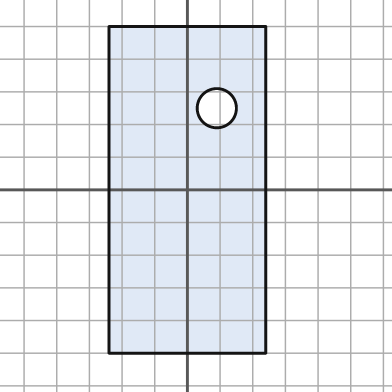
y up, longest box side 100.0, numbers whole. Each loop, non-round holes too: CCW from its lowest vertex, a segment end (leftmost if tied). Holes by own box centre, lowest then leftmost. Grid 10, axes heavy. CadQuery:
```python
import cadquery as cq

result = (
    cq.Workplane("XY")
    .moveTo(-24.0, -50.0)
    .lineTo(24.0, -50.0)
    .lineTo(24.0, 50.0)
    .lineTo(-24.0, 50.0)
    .close()
    .moveTo(9.0, 25.0)
    .circle(6.0)
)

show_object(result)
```